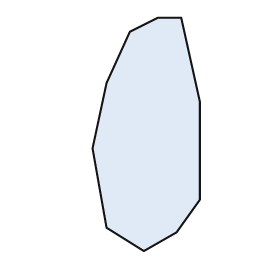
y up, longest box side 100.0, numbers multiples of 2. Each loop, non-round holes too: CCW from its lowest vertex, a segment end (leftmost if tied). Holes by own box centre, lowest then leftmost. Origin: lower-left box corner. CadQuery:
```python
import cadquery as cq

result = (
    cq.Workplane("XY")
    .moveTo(22.0, 0.0)
    .lineTo(36.0, 8.0)
    .lineTo(46.0, 22.0)
    .lineTo(46.0, 64.0)
    .lineTo(38.0, 100.0)
    .lineTo(28.0, 100.0)
    .lineTo(16.0, 94.0)
    .lineTo(6.0, 72.0)
    .lineTo(0.0, 44.0)
    .lineTo(6.0, 10.0)
    .close()
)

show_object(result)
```